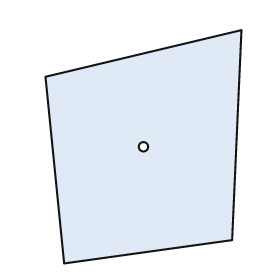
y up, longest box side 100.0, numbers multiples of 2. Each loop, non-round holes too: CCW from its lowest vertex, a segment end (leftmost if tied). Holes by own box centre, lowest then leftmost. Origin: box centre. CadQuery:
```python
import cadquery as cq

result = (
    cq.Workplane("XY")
    .moveTo(-34.0, -50.0)
    .lineTo(38.0, -40.0)
    .lineTo(42.0, 50.0)
    .lineTo(-42.0, 30.0)
    .close()
    .moveTo(0.0, 0.0)
    .circle(2.0)
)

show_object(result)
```